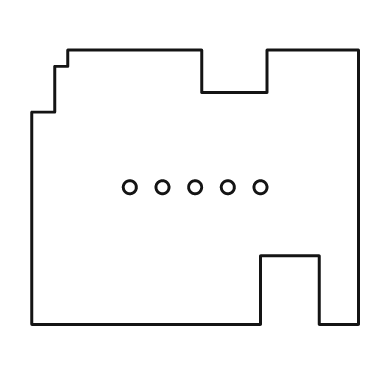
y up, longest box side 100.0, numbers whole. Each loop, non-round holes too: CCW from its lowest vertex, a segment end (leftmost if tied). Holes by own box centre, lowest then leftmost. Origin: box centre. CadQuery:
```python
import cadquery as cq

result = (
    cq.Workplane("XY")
    .moveTo(-50.0, -42.0)
    .lineTo(20.0, -42.0)
    .lineTo(20.0, -21.0)
    .lineTo(38.0, -21.0)
    .lineTo(38.0, -42.0)
    .lineTo(50.0, -42.0)
    .lineTo(50.0, 42.0)
    .lineTo(22.0, 42.0)
    .lineTo(22.0, 29.0)
    .lineTo(2.0, 29.0)
    .lineTo(2.0, 42.0)
    .lineTo(-39.0, 42.0)
    .lineTo(-39.0, 37.0)
    .lineTo(-43.0, 37.0)
    .lineTo(-43.0, 23.0)
    .lineTo(-50.0, 23.0)
    .close()
    .moveTo(-20.0, 0.0)
    .circle(2.0)
    .moveTo(-10.0, 0.0)
    .circle(2.0)
    .moveTo(0.0, 0.0)
    .circle(2.0)
    .moveTo(10.0, 0.0)
    .circle(2.0)
    .moveTo(20.0, 0.0)
    .circle(2.0)
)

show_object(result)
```